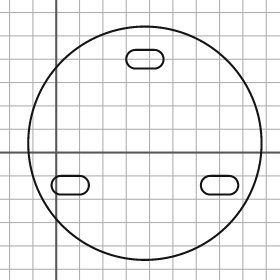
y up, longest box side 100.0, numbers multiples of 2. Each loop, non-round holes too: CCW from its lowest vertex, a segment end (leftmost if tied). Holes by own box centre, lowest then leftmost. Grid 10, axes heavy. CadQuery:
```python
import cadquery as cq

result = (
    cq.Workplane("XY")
    .moveTo(38.0, 4.0)
    .circle(50.0)
    .moveTo(2.0, -18.0)
    .lineTo(10.0, -18.0)
    .threePointArc((14.0, -14.0), (10.0, -10.0))
    .lineTo(2.0, -10.0)
    .threePointArc((-2.0, -14.0), (2.0, -18.0))
    .close()
    .moveTo(66.0, -18.0)
    .lineTo(74.0, -18.0)
    .threePointArc((78.0, -14.0), (74.0, -10.0))
    .lineTo(66.0, -10.0)
    .threePointArc((62.0, -14.0), (66.0, -18.0))
    .close()
    .moveTo(34.0, 36.0)
    .lineTo(42.0, 36.0)
    .threePointArc((46.0, 40.0), (42.0, 44.0))
    .lineTo(34.0, 44.0)
    .threePointArc((30.0, 40.0), (34.0, 36.0))
    .close()
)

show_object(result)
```